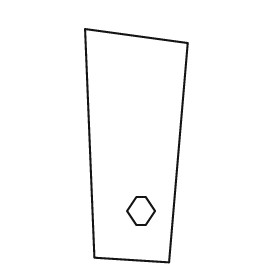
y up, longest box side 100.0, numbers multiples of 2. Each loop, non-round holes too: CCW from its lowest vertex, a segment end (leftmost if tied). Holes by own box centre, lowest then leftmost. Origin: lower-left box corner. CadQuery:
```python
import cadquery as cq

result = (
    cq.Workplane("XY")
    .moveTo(36.0, 0.0)
    .lineTo(44.0, 94.0)
    .lineTo(0.0, 100.0)
    .lineTo(4.0, 2.0)
    .close()
    .moveTo(22.0, 16.0)
    .lineTo(26.0, 16.0)
    .lineTo(30.0, 22.0)
    .lineTo(26.0, 28.0)
    .lineTo(22.0, 28.0)
    .lineTo(18.0, 22.0)
    .close()
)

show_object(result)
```